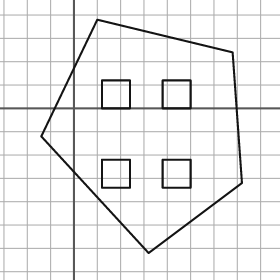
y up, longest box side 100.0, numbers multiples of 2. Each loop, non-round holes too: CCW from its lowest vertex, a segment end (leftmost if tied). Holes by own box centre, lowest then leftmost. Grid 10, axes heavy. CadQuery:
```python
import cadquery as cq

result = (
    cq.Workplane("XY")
    .moveTo(32.0, -62.0)
    .lineTo(72.0, -32.0)
    .lineTo(68.0, 24.0)
    .lineTo(10.0, 38.0)
    .lineTo(-14.0, -12.0)
    .close()
    .moveTo(12.0, -34.0)
    .lineTo(24.0, -34.0)
    .lineTo(24.0, -22.0)
    .lineTo(12.0, -22.0)
    .close()
    .moveTo(38.0, -34.0)
    .lineTo(50.0, -34.0)
    .lineTo(50.0, -22.0)
    .lineTo(38.0, -22.0)
    .close()
    .moveTo(12.0, 0.0)
    .lineTo(24.0, 0.0)
    .lineTo(24.0, 12.0)
    .lineTo(12.0, 12.0)
    .close()
    .moveTo(38.0, 0.0)
    .lineTo(50.0, 0.0)
    .lineTo(50.0, 12.0)
    .lineTo(38.0, 12.0)
    .close()
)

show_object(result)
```